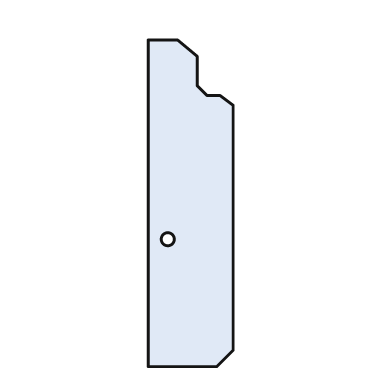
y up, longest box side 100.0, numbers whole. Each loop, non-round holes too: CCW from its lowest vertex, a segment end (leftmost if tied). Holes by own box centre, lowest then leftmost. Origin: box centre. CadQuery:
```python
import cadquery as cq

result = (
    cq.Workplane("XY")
    .moveTo(-13.0, -50.0)
    .lineTo(8.0, -50.0)
    .lineTo(13.0, -45.0)
    .lineTo(13.0, 30.0)
    .lineTo(9.0, 33.0)
    .lineTo(5.0, 33.0)
    .lineTo(2.0, 36.0)
    .lineTo(2.0, 45.0)
    .lineTo(-4.0, 50.0)
    .lineTo(-13.0, 50.0)
    .close()
    .moveTo(-7.0, -11.0)
    .circle(2.0)
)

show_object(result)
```